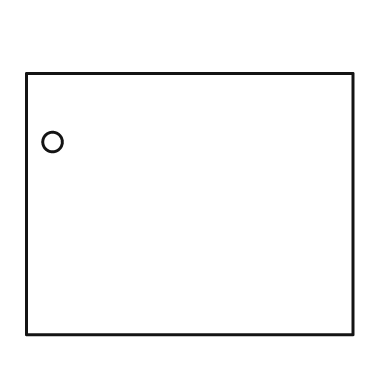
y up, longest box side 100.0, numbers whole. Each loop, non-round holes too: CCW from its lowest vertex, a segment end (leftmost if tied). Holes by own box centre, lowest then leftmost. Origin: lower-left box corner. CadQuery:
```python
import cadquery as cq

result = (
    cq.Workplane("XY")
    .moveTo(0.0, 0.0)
    .lineTo(100.0, 0.0)
    .lineTo(100.0, 80.0)
    .lineTo(0.0, 80.0)
    .close()
    .moveTo(8.0, 59.0)
    .circle(3.0)
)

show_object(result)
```